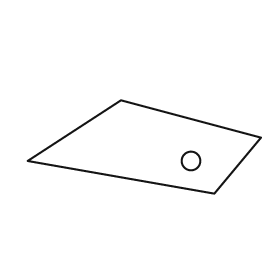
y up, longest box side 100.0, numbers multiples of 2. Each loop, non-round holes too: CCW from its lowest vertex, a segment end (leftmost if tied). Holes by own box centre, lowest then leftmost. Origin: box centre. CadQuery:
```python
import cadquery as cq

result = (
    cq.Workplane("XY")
    .moveTo(30.0, -20.0)
    .lineTo(50.0, 4.0)
    .lineTo(-10.0, 20.0)
    .lineTo(-50.0, -6.0)
    .close()
    .moveTo(20.0, -6.0)
    .circle(4.0)
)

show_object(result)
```